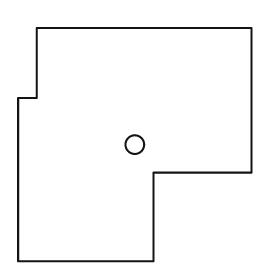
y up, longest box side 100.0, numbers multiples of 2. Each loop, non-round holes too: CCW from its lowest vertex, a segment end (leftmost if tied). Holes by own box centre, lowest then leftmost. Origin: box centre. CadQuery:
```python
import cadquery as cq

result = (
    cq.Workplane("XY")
    .moveTo(-50.0, -50.0)
    .lineTo(8.0, -50.0)
    .lineTo(8.0, -12.0)
    .lineTo(50.0, -12.0)
    .lineTo(50.0, 50.0)
    .lineTo(-42.0, 50.0)
    .lineTo(-42.0, 20.0)
    .lineTo(-50.0, 20.0)
    .close()
    .moveTo(0.0, 0.0)
    .circle(4.0)
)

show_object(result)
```